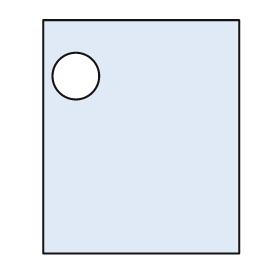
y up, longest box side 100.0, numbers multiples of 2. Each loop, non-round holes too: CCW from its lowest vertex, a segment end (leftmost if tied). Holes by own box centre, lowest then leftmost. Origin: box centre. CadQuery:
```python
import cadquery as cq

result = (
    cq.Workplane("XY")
    .moveTo(-42.0, -50.0)
    .lineTo(42.0, -50.0)
    .lineTo(42.0, 50.0)
    .lineTo(-42.0, 50.0)
    .close()
    .moveTo(-28.0, 26.0)
    .circle(10.0)
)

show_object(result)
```